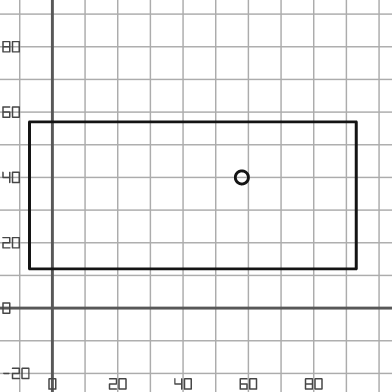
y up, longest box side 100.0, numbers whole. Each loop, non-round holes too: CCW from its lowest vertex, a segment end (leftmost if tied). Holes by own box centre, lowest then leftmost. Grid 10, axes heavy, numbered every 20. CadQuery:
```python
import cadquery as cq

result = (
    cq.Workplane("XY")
    .moveTo(-7.0, 12.0)
    .lineTo(93.0, 12.0)
    .lineTo(93.0, 57.0)
    .lineTo(-7.0, 57.0)
    .close()
    .moveTo(58.0, 40.0)
    .circle(2.0)
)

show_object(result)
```